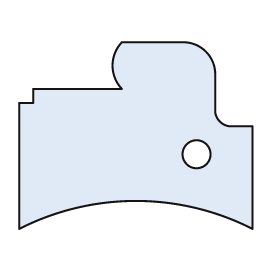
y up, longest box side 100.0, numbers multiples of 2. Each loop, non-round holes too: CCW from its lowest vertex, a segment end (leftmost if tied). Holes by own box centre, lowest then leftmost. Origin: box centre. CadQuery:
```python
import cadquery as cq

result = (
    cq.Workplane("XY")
    .moveTo(-50.0, -40.0)
    .threePointArc((0.0, -28.0), (50.0, -40.0))
    .lineTo(50.0, 4.0)
    .lineTo(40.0, 4.0)
    .threePointArc((36.0, 6.0), (34.0, 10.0))
    .lineTo(34.0, 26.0)
    .threePointArc((30.0, 36.0), (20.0, 40.0))
    .lineTo(-6.0, 40.0)
    .threePointArc((-10.0, 30.0), (-6.0, 20.0))
    .lineTo(-44.0, 20.0)
    .lineTo(-44.0, 14.0)
    .lineTo(-50.0, 14.0)
    .close()
    .moveTo(26.0, -8.0)
    .circle(6.0)
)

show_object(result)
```